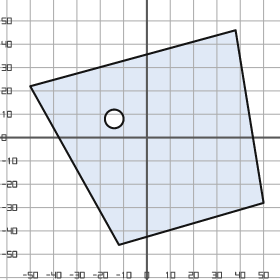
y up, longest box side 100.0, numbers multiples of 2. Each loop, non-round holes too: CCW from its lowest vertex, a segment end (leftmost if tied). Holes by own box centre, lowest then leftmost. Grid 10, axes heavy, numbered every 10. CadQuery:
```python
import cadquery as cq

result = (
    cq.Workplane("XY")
    .moveTo(-12.0, -46.0)
    .lineTo(50.0, -28.0)
    .lineTo(38.0, 46.0)
    .lineTo(-50.0, 22.0)
    .close()
    .moveTo(-14.0, 8.0)
    .circle(4.0)
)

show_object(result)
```